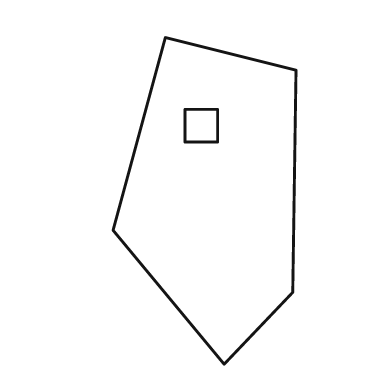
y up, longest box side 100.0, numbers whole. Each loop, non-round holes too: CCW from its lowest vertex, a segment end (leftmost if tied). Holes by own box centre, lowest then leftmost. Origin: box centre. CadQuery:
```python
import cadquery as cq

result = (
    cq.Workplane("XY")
    .moveTo(6.0, -50.0)
    .lineTo(27.0, -28.0)
    .lineTo(28.0, 40.0)
    .lineTo(-12.0, 50.0)
    .lineTo(-28.0, -9.0)
    .close()
    .moveTo(-6.0, 18.0)
    .lineTo(4.0, 18.0)
    .lineTo(4.0, 28.0)
    .lineTo(-6.0, 28.0)
    .close()
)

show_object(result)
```